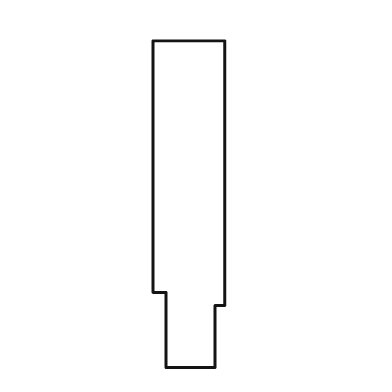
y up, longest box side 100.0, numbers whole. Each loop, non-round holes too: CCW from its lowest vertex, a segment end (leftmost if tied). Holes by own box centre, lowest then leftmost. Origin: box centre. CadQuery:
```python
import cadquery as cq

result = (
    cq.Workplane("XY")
    .moveTo(-7.0, -50.0)
    .lineTo(8.0, -50.0)
    .lineTo(8.0, -31.0)
    .lineTo(11.0, -31.0)
    .lineTo(11.0, 50.0)
    .lineTo(-11.0, 50.0)
    .lineTo(-11.0, -27.0)
    .lineTo(-7.0, -27.0)
    .close()
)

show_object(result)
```